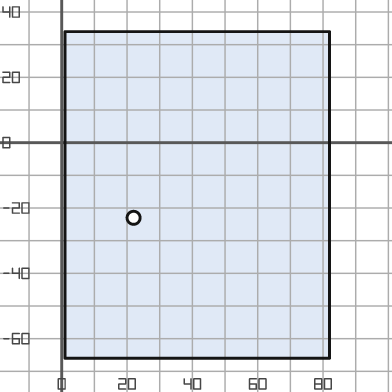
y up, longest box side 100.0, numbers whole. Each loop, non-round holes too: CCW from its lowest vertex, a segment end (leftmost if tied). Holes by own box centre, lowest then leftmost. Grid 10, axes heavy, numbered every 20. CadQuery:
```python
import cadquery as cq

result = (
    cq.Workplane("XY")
    .moveTo(1.0, -66.0)
    .lineTo(82.0, -66.0)
    .lineTo(82.0, 34.0)
    .lineTo(1.0, 34.0)
    .close()
    .moveTo(22.0, -23.0)
    .circle(2.0)
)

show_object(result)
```